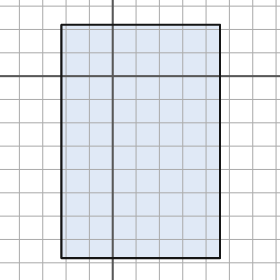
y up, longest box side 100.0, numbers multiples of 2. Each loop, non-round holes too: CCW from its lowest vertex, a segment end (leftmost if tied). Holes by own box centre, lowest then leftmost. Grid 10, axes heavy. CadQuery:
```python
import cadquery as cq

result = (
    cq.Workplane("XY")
    .moveTo(-22.0, -78.0)
    .lineTo(46.0, -78.0)
    .lineTo(46.0, 22.0)
    .lineTo(-22.0, 22.0)
    .close()
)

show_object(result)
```